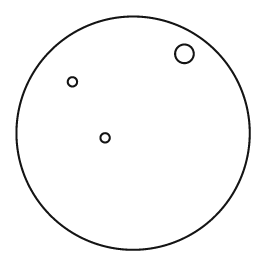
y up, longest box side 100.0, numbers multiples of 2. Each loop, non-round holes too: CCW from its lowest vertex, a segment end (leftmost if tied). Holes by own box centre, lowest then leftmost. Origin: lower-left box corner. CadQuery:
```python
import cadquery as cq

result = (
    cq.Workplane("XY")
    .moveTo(50.0, 50.0)
    .circle(50.0)
    .moveTo(38.0, 48.0)
    .circle(2.0)
    .moveTo(24.0, 72.0)
    .circle(2.0)
    .moveTo(72.0, 84.0)
    .circle(4.0)
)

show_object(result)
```